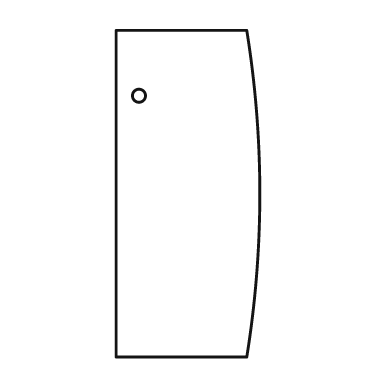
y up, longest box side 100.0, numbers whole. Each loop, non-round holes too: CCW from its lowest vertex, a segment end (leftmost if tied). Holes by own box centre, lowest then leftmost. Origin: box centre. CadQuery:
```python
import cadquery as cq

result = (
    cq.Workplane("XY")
    .moveTo(-22.0, -50.0)
    .lineTo(18.0, -50.0)
    .threePointArc((22.0, 0.0), (18.0, 50.0))
    .lineTo(-22.0, 50.0)
    .close()
    .moveTo(-15.0, 30.0)
    .circle(2.0)
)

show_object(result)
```